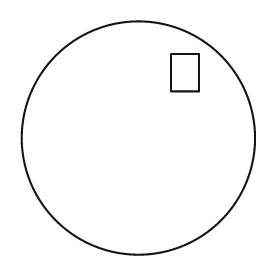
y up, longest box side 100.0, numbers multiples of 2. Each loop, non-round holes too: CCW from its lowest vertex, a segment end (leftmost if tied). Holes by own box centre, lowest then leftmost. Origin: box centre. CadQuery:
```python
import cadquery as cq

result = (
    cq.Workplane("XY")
    .moveTo(0.0, 0.0)
    .circle(50.0)
    .moveTo(14.0, 20.0)
    .lineTo(26.0, 20.0)
    .lineTo(26.0, 36.0)
    .lineTo(14.0, 36.0)
    .close()
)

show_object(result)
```